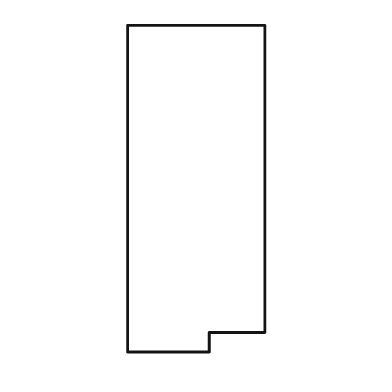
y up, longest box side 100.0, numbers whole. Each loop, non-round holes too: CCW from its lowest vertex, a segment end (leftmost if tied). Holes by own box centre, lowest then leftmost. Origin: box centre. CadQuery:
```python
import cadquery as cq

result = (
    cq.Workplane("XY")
    .moveTo(-21.0, -50.0)
    .lineTo(4.0, -50.0)
    .lineTo(4.0, -44.0)
    .lineTo(21.0, -44.0)
    .lineTo(21.0, 50.0)
    .lineTo(-21.0, 50.0)
    .close()
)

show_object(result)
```